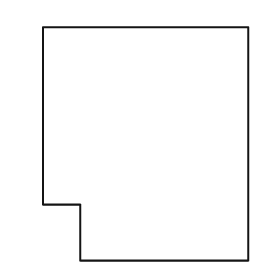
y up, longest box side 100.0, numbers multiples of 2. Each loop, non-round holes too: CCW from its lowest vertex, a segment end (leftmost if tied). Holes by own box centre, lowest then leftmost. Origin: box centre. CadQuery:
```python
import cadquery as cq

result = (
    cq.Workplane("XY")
    .moveTo(-28.0, -50.0)
    .lineTo(44.0, -50.0)
    .lineTo(44.0, 50.0)
    .lineTo(-44.0, 50.0)
    .lineTo(-44.0, -26.0)
    .lineTo(-28.0, -26.0)
    .close()
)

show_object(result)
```